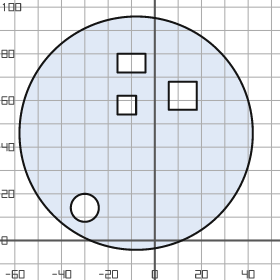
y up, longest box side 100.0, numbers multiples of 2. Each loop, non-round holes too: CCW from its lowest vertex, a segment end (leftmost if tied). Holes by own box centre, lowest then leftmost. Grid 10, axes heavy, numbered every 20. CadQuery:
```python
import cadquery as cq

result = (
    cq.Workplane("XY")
    .moveTo(-8.0, 46.0)
    .circle(50.0)
    .moveTo(-30.0, 14.0)
    .circle(6.0)
    .moveTo(-16.0, 54.0)
    .lineTo(-8.0, 54.0)
    .lineTo(-8.0, 62.0)
    .lineTo(-16.0, 62.0)
    .close()
    .moveTo(6.0, 56.0)
    .lineTo(18.0, 56.0)
    .lineTo(18.0, 68.0)
    .lineTo(6.0, 68.0)
    .close()
    .moveTo(-16.0, 72.0)
    .lineTo(-4.0, 72.0)
    .lineTo(-4.0, 80.0)
    .lineTo(-16.0, 80.0)
    .close()
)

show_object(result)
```